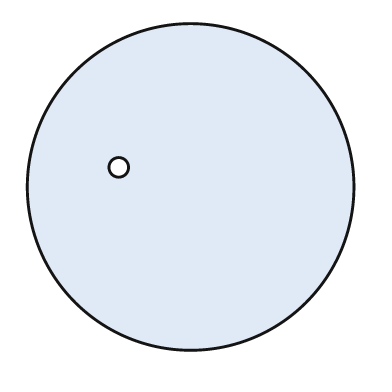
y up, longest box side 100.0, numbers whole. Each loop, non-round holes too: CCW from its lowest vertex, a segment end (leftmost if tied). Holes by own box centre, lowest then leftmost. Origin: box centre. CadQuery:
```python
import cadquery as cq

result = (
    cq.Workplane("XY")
    .moveTo(0.0, 0.0)
    .circle(50.0)
    .moveTo(-22.0, 6.0)
    .circle(3.0)
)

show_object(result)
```